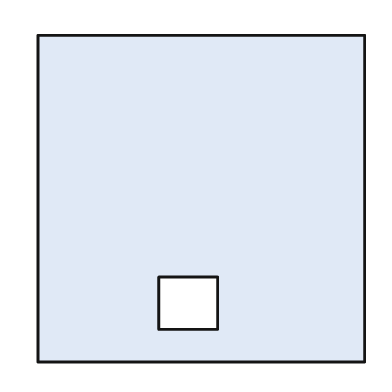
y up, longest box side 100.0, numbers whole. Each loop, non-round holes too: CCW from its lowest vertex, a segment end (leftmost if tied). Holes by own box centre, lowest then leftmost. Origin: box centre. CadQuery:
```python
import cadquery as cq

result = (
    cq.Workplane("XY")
    .moveTo(-50.0, -50.0)
    .lineTo(50.0, -50.0)
    .lineTo(50.0, 50.0)
    .lineTo(-50.0, 50.0)
    .close()
    .moveTo(-13.0, -40.0)
    .lineTo(5.0, -40.0)
    .lineTo(5.0, -24.0)
    .lineTo(-13.0, -24.0)
    .close()
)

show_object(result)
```